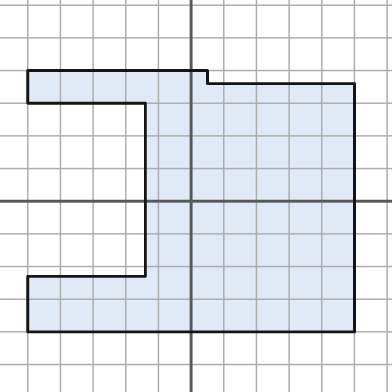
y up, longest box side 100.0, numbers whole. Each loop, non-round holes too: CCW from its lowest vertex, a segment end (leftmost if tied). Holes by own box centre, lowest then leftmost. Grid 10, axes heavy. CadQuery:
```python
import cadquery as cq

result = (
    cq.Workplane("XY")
    .moveTo(-50.0, -40.0)
    .lineTo(50.0, -40.0)
    .lineTo(50.0, 36.0)
    .lineTo(5.0, 36.0)
    .lineTo(5.0, 40.0)
    .lineTo(-50.0, 40.0)
    .lineTo(-50.0, 30.0)
    .lineTo(-14.0, 30.0)
    .lineTo(-14.0, -23.0)
    .lineTo(-50.0, -23.0)
    .close()
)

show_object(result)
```